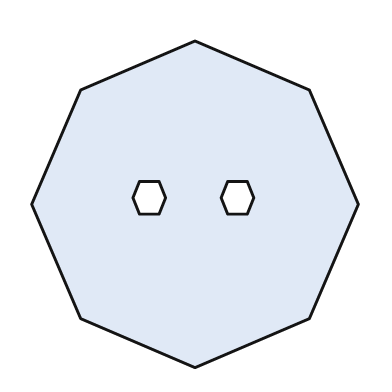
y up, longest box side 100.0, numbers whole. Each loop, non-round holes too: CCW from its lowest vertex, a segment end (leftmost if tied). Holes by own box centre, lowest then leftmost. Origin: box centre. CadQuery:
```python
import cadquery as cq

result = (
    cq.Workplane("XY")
    .moveTo(0.0, -50.0)
    .lineTo(35.0, -35.0)
    .lineTo(50.0, 0.0)
    .lineTo(35.0, 35.0)
    .lineTo(0.0, 50.0)
    .lineTo(-35.0, 35.0)
    .lineTo(-50.0, 0.0)
    .lineTo(-35.0, -35.0)
    .close()
    .moveTo(-17.0, -3.0)
    .lineTo(-11.0, -3.0)
    .lineTo(-9.0, 2.0)
    .lineTo(-11.0, 7.0)
    .lineTo(-17.0, 7.0)
    .lineTo(-19.0, 2.0)
    .close()
    .moveTo(10.0, -3.0)
    .lineTo(16.0, -3.0)
    .lineTo(18.0, 2.0)
    .lineTo(16.0, 7.0)
    .lineTo(10.0, 7.0)
    .lineTo(8.0, 2.0)
    .close()
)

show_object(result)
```